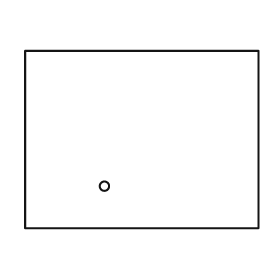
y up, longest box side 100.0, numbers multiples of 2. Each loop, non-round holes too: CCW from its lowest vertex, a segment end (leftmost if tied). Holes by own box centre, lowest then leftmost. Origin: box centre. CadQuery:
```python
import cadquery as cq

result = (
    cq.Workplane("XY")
    .moveTo(-50.0, -38.0)
    .lineTo(50.0, -38.0)
    .lineTo(50.0, 38.0)
    .lineTo(-50.0, 38.0)
    .close()
    .moveTo(-16.0, -20.0)
    .circle(2.0)
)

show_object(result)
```